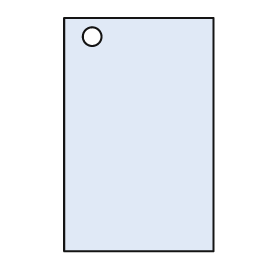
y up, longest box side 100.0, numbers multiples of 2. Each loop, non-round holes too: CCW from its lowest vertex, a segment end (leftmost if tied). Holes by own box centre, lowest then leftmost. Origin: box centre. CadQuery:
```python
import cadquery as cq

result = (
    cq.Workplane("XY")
    .moveTo(-32.0, -50.0)
    .lineTo(32.0, -50.0)
    .lineTo(32.0, 50.0)
    .lineTo(-32.0, 50.0)
    .close()
    .moveTo(-20.0, 42.0)
    .circle(4.0)
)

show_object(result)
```